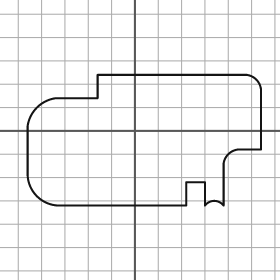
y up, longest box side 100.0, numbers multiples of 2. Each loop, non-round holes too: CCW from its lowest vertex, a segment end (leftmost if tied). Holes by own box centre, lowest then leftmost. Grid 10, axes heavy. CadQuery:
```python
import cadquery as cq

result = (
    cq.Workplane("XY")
    .moveTo(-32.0, -32.0)
    .lineTo(22.0, -32.0)
    .lineTo(22.0, -22.0)
    .lineTo(30.0, -22.0)
    .lineTo(30.0, -32.0)
    .threePointArc((34.0, -30.0), (38.0, -32.0))
    .lineTo(38.0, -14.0)
    .threePointArc((40.0, -10.0), (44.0, -8.0))
    .lineTo(54.0, -8.0)
    .lineTo(54.0, 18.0)
    .threePointArc((52.0, 22.0), (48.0, 24.0))
    .lineTo(-16.0, 24.0)
    .lineTo(-16.0, 14.0)
    .lineTo(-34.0, 14.0)
    .threePointArc((-42.0, 10.0), (-46.0, 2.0))
    .lineTo(-46.0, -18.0)
    .threePointArc((-42.0, -28.0), (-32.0, -32.0))
    .close()
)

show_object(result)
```